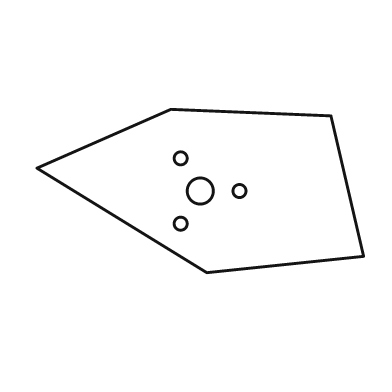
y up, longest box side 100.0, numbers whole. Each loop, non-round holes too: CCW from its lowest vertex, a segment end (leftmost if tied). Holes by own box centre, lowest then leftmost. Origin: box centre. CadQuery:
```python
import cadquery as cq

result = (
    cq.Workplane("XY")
    .moveTo(2.0, -25.0)
    .lineTo(50.0, -20.0)
    .lineTo(40.0, 23.0)
    .lineTo(-9.0, 25.0)
    .lineTo(-50.0, 7.0)
    .close()
    .moveTo(-6.0, -10.0)
    .circle(2.0)
    .moveTo(0.0, 0.0)
    .circle(4.0)
    .moveTo(12.0, 0.0)
    .circle(2.0)
    .moveTo(-6.0, 10.0)
    .circle(2.0)
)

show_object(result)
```